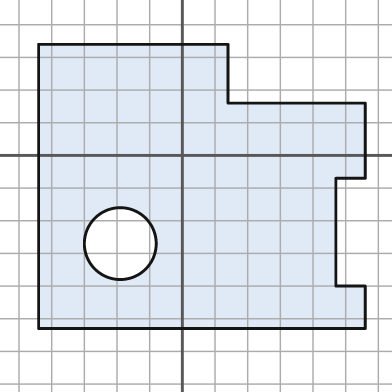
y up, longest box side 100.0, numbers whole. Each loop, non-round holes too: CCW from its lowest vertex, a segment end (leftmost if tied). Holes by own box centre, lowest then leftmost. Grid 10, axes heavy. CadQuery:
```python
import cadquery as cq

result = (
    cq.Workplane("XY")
    .moveTo(-44.0, -53.0)
    .lineTo(56.0, -53.0)
    .lineTo(56.0, -40.0)
    .lineTo(47.0, -40.0)
    .lineTo(47.0, -7.0)
    .lineTo(56.0, -7.0)
    .lineTo(56.0, 16.0)
    .lineTo(14.0, 16.0)
    .lineTo(14.0, 34.0)
    .lineTo(-44.0, 34.0)
    .close()
    .moveTo(-19.0, -27.0)
    .circle(11.0)
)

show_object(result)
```